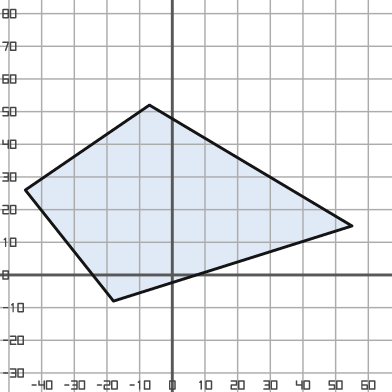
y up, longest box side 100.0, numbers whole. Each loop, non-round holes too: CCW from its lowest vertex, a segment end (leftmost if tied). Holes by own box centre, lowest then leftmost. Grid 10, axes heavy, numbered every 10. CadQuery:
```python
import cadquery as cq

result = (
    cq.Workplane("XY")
    .moveTo(-18.0, -8.0)
    .lineTo(55.0, 15.0)
    .lineTo(-7.0, 52.0)
    .lineTo(-45.0, 26.0)
    .close()
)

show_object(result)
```